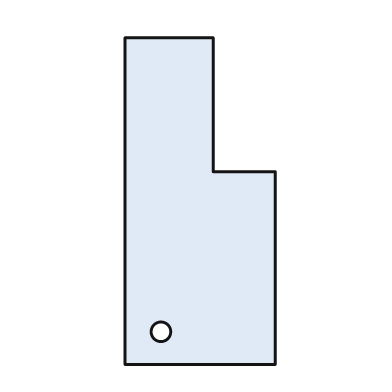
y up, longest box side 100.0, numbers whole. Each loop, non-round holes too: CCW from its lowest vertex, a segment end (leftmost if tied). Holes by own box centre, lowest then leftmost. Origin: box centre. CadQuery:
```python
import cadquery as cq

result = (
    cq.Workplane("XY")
    .moveTo(-23.0, -50.0)
    .lineTo(23.0, -50.0)
    .lineTo(23.0, 9.0)
    .lineTo(4.0, 9.0)
    .lineTo(4.0, 50.0)
    .lineTo(-23.0, 50.0)
    .close()
    .moveTo(-12.0, -40.0)
    .circle(3.0)
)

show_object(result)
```